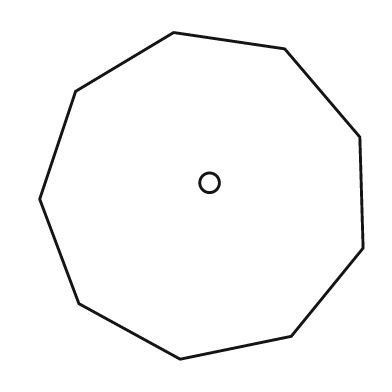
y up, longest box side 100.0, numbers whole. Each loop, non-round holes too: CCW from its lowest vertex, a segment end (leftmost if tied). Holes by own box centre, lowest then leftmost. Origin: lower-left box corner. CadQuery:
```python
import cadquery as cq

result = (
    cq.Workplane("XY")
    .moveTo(43.0, 0.0)
    .lineTo(77.0, 7.0)
    .lineTo(99.0, 34.0)
    .lineTo(98.0, 68.0)
    .lineTo(75.0, 95.0)
    .lineTo(41.0, 100.0)
    .lineTo(11.0, 82.0)
    .lineTo(0.0, 49.0)
    .lineTo(12.0, 17.0)
    .close()
    .moveTo(52.0, 54.0)
    .circle(3.0)
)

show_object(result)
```